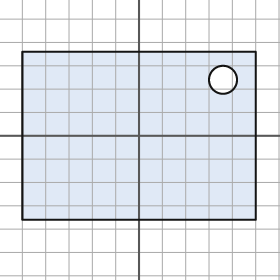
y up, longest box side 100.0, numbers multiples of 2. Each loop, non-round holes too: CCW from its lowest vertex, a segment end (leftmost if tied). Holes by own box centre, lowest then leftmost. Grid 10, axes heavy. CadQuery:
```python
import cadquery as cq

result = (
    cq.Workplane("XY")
    .moveTo(-50.0, -36.0)
    .lineTo(50.0, -36.0)
    .lineTo(50.0, 36.0)
    .lineTo(-50.0, 36.0)
    .close()
    .moveTo(36.0, 24.0)
    .circle(6.0)
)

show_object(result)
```